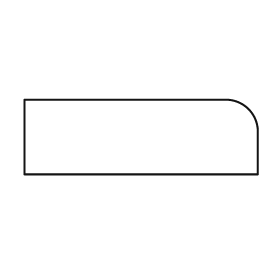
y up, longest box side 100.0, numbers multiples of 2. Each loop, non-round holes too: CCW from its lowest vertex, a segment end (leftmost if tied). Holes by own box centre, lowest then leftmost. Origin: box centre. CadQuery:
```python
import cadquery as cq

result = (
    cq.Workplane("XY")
    .moveTo(-50.0, -16.0)
    .lineTo(50.0, -16.0)
    .lineTo(50.0, 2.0)
    .threePointArc((46.0, 12.0), (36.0, 16.0))
    .lineTo(-50.0, 16.0)
    .close()
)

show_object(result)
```